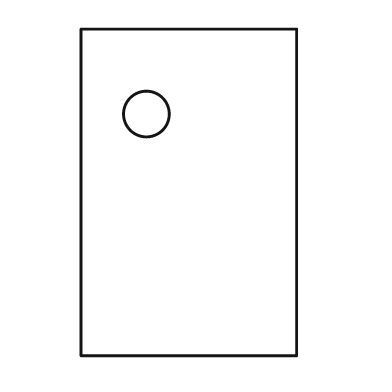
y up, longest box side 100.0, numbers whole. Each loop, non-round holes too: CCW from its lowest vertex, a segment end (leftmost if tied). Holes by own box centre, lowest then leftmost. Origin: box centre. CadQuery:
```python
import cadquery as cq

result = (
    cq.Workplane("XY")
    .moveTo(-33.0, -50.0)
    .lineTo(33.0, -50.0)
    .lineTo(33.0, 50.0)
    .lineTo(-33.0, 50.0)
    .close()
    .moveTo(-13.0, 24.0)
    .circle(7.0)
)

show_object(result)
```